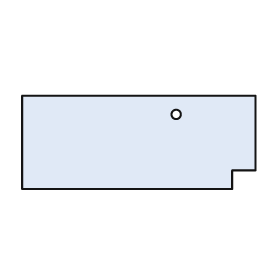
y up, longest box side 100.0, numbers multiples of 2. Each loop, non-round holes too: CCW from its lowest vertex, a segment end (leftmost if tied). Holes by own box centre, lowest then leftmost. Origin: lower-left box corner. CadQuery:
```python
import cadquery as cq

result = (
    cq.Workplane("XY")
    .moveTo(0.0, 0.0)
    .lineTo(90.0, 0.0)
    .lineTo(90.0, 8.0)
    .lineTo(100.0, 8.0)
    .lineTo(100.0, 40.0)
    .lineTo(0.0, 40.0)
    .close()
    .moveTo(66.0, 32.0)
    .circle(2.0)
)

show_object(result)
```